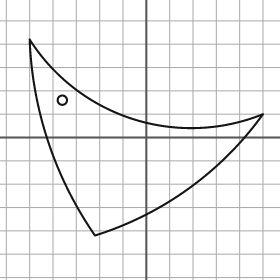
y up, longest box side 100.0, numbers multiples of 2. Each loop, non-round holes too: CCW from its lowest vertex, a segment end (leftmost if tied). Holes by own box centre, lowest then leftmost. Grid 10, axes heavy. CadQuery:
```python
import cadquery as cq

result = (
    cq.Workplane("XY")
    .moveTo(-22.0, -42.0)
    .threePointArc((18.0, -22.0), (50.0, 10.0))
    .threePointArc((-6.0, 8.0), (-50.0, 42.0))
    .threePointArc((-42.0, -2.0), (-22.0, -42.0))
    .close()
    .moveTo(-36.0, 16.0)
    .circle(2.0)
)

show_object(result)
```